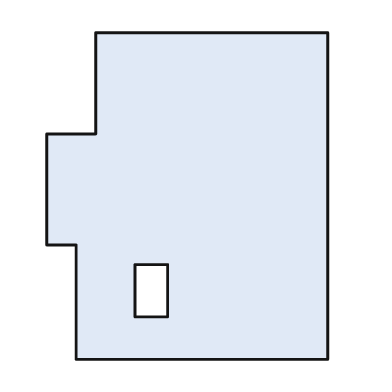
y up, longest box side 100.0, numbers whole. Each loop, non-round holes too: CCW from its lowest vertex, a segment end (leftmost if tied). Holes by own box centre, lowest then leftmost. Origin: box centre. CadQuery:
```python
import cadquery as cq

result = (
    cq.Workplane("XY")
    .moveTo(-34.0, -50.0)
    .lineTo(43.0, -50.0)
    .lineTo(43.0, 50.0)
    .lineTo(-28.0, 50.0)
    .lineTo(-28.0, 19.0)
    .lineTo(-43.0, 19.0)
    .lineTo(-43.0, -15.0)
    .lineTo(-34.0, -15.0)
    .close()
    .moveTo(-16.0, -37.0)
    .lineTo(-6.0, -37.0)
    .lineTo(-6.0, -21.0)
    .lineTo(-16.0, -21.0)
    .close()
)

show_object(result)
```